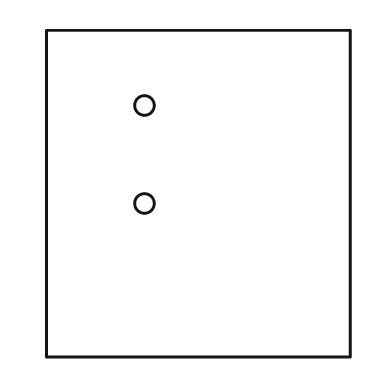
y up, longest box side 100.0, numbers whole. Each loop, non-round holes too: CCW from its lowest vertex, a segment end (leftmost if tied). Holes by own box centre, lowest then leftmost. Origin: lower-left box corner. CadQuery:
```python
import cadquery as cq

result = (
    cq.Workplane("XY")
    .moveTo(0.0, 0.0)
    .lineTo(93.0, 0.0)
    .lineTo(93.0, 100.0)
    .lineTo(0.0, 100.0)
    .close()
    .moveTo(30.0, 47.0)
    .circle(3.0)
    .moveTo(30.0, 77.0)
    .circle(3.0)
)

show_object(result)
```